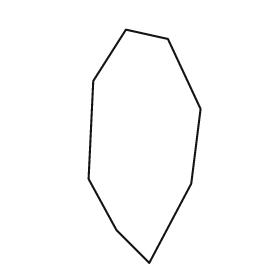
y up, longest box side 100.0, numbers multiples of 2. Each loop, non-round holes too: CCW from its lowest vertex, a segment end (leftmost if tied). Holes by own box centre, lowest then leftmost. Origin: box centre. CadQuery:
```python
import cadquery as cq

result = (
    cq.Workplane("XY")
    .moveTo(2.0, -50.0)
    .lineTo(20.0, -16.0)
    .lineTo(24.0, 16.0)
    .lineTo(10.0, 46.0)
    .lineTo(-8.0, 50.0)
    .lineTo(-22.0, 28.0)
    .lineTo(-24.0, -14.0)
    .lineTo(-12.0, -36.0)
    .close()
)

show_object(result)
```